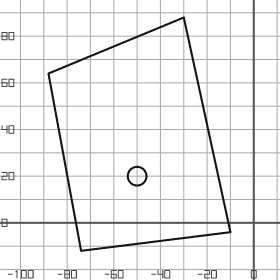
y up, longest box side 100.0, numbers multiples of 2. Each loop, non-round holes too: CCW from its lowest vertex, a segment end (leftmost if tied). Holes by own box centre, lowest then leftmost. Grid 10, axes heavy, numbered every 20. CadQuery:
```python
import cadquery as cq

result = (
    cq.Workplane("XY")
    .moveTo(-74.0, -12.0)
    .lineTo(-10.0, -4.0)
    .lineTo(-30.0, 88.0)
    .lineTo(-88.0, 64.0)
    .close()
    .moveTo(-50.0, 20.0)
    .circle(4.0)
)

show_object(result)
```